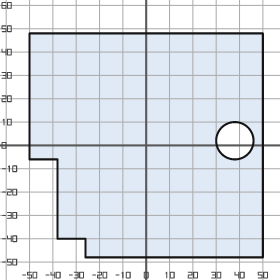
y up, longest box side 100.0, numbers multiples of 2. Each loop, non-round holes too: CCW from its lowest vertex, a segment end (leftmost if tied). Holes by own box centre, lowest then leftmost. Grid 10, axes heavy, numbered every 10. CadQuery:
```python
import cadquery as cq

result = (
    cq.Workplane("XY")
    .moveTo(-26.0, -48.0)
    .lineTo(50.0, -48.0)
    .lineTo(50.0, 48.0)
    .lineTo(-50.0, 48.0)
    .lineTo(-50.0, -6.0)
    .lineTo(-38.0, -6.0)
    .lineTo(-38.0, -40.0)
    .lineTo(-26.0, -40.0)
    .close()
    .moveTo(38.0, 2.0)
    .circle(8.0)
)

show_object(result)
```